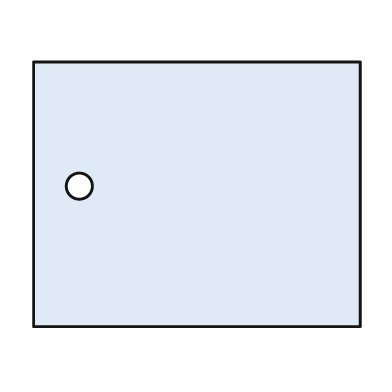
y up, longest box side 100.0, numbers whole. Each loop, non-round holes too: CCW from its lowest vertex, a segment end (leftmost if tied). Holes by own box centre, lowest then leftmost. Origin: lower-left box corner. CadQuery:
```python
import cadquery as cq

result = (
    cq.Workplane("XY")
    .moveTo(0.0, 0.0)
    .lineTo(100.0, 0.0)
    .lineTo(100.0, 81.0)
    .lineTo(0.0, 81.0)
    .close()
    .moveTo(14.0, 43.0)
    .circle(4.0)
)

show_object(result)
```